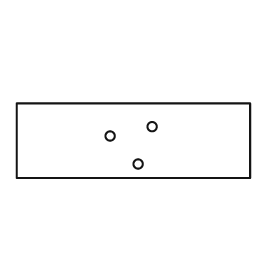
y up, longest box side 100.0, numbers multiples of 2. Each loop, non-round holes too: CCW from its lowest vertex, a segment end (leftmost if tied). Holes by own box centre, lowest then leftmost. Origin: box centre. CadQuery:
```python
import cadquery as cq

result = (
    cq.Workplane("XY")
    .moveTo(-50.0, -16.0)
    .lineTo(50.0, -16.0)
    .lineTo(50.0, 16.0)
    .lineTo(-50.0, 16.0)
    .close()
    .moveTo(2.0, -10.0)
    .circle(2.0)
    .moveTo(-10.0, 2.0)
    .circle(2.0)
    .moveTo(8.0, 6.0)
    .circle(2.0)
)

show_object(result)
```